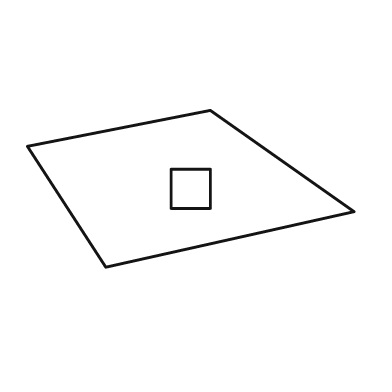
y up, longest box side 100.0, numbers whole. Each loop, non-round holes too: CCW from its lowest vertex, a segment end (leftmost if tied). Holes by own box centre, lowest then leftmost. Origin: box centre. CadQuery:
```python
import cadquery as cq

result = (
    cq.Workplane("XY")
    .moveTo(-26.0, -24.0)
    .lineTo(50.0, -7.0)
    .lineTo(6.0, 24.0)
    .lineTo(-50.0, 13.0)
    .close()
    .moveTo(-6.0, -6.0)
    .lineTo(6.0, -6.0)
    .lineTo(6.0, 6.0)
    .lineTo(-6.0, 6.0)
    .close()
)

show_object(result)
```